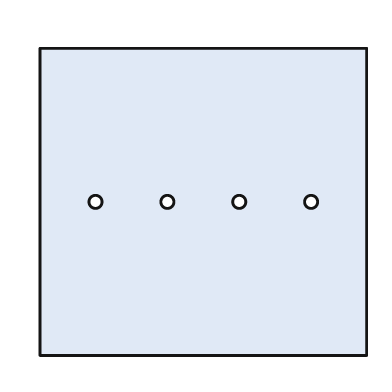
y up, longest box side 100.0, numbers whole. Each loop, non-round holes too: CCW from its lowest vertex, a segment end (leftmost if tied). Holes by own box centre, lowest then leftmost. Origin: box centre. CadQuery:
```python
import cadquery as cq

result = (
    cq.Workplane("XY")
    .moveTo(-50.0, -47.0)
    .lineTo(50.0, -47.0)
    .lineTo(50.0, 47.0)
    .lineTo(-50.0, 47.0)
    .close()
    .moveTo(-33.0, 0.0)
    .circle(2.0)
    .moveTo(-11.0, 0.0)
    .circle(2.0)
    .moveTo(11.0, 0.0)
    .circle(2.0)
    .moveTo(33.0, 0.0)
    .circle(2.0)
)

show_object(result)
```